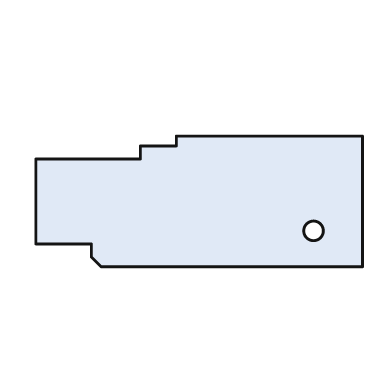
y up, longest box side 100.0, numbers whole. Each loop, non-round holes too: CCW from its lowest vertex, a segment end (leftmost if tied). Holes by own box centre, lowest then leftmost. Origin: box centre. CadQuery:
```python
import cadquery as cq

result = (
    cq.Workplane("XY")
    .moveTo(-30.0, -20.0)
    .lineTo(50.0, -20.0)
    .lineTo(50.0, 20.0)
    .lineTo(-7.0, 20.0)
    .lineTo(-7.0, 17.0)
    .lineTo(-18.0, 17.0)
    .lineTo(-18.0, 13.0)
    .lineTo(-50.0, 13.0)
    .lineTo(-50.0, -13.0)
    .lineTo(-33.0, -13.0)
    .lineTo(-33.0, -17.0)
    .close()
    .moveTo(35.0, -9.0)
    .circle(3.0)
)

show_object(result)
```